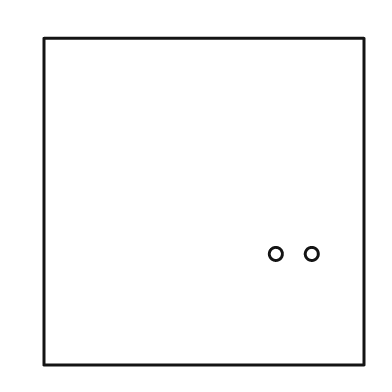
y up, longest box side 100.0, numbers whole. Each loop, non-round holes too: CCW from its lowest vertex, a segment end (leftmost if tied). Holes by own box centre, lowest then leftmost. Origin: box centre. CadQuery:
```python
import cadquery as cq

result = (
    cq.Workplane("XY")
    .moveTo(-49.0, -50.0)
    .lineTo(49.0, -50.0)
    .lineTo(49.0, 50.0)
    .lineTo(-49.0, 50.0)
    .close()
    .moveTo(22.0, -16.0)
    .circle(2.0)
    .moveTo(33.0, -16.0)
    .circle(2.0)
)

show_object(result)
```